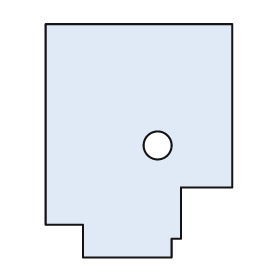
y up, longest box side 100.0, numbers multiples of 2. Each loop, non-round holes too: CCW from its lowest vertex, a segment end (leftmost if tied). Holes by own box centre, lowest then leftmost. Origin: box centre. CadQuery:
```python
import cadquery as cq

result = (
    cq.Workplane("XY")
    .moveTo(-24.0, -50.0)
    .lineTo(14.0, -50.0)
    .lineTo(14.0, -42.0)
    .lineTo(18.0, -42.0)
    .lineTo(18.0, -20.0)
    .lineTo(40.0, -20.0)
    .lineTo(40.0, 50.0)
    .lineTo(-40.0, 50.0)
    .lineTo(-40.0, -36.0)
    .lineTo(-24.0, -36.0)
    .close()
    .moveTo(8.0, -2.0)
    .circle(6.0)
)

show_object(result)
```